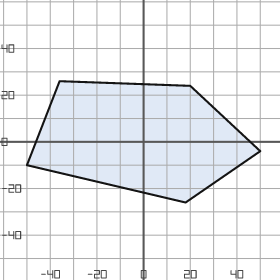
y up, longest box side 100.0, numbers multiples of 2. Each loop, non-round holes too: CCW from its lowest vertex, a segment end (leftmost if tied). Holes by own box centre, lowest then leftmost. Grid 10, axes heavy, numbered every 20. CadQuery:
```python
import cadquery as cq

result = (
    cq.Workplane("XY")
    .moveTo(18.0, -26.0)
    .lineTo(50.0, -4.0)
    .lineTo(20.0, 24.0)
    .lineTo(-36.0, 26.0)
    .lineTo(-50.0, -10.0)
    .close()
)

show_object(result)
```